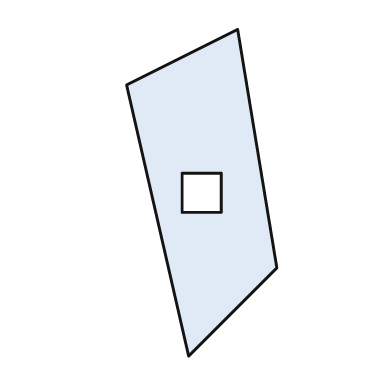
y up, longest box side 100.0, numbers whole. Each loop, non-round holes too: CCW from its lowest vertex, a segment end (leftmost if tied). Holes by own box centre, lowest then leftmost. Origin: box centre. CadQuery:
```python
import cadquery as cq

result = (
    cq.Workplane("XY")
    .moveTo(-4.0, -50.0)
    .lineTo(23.0, -23.0)
    .lineTo(11.0, 50.0)
    .lineTo(-23.0, 33.0)
    .close()
    .moveTo(-6.0, -6.0)
    .lineTo(6.0, -6.0)
    .lineTo(6.0, 6.0)
    .lineTo(-6.0, 6.0)
    .close()
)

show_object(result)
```